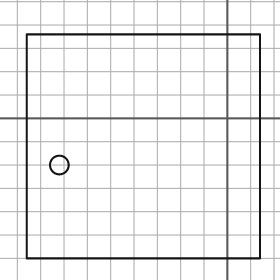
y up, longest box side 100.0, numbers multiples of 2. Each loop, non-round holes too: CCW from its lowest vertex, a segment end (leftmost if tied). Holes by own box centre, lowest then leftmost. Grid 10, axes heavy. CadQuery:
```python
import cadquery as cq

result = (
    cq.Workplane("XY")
    .moveTo(-86.0, -60.0)
    .lineTo(14.0, -60.0)
    .lineTo(14.0, 36.0)
    .lineTo(-86.0, 36.0)
    .close()
    .moveTo(-72.0, -20.0)
    .circle(4.0)
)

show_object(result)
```